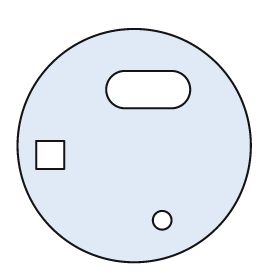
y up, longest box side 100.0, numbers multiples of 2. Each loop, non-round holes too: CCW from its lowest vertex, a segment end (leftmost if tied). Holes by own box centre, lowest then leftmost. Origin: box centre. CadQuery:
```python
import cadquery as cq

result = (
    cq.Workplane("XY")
    .moveTo(0.0, 0.0)
    .circle(50.0)
    .moveTo(12.0, -32.0)
    .circle(4.0)
    .moveTo(-42.0, -10.0)
    .lineTo(-30.0, -10.0)
    .lineTo(-30.0, 2.0)
    .lineTo(-42.0, 2.0)
    .close()
    .moveTo(-4.0, 16.0)
    .lineTo(16.0, 16.0)
    .threePointArc((24.0, 24.0), (16.0, 32.0))
    .lineTo(-4.0, 32.0)
    .threePointArc((-12.0, 24.0), (-4.0, 16.0))
    .close()
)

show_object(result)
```